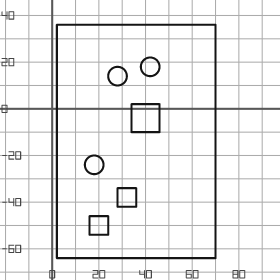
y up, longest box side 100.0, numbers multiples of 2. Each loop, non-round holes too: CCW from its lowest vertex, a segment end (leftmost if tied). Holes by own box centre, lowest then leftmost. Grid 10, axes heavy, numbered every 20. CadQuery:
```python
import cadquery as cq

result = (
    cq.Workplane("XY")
    .moveTo(2.0, -64.0)
    .lineTo(70.0, -64.0)
    .lineTo(70.0, 36.0)
    .lineTo(2.0, 36.0)
    .close()
    .moveTo(16.0, -54.0)
    .lineTo(24.0, -54.0)
    .lineTo(24.0, -46.0)
    .lineTo(16.0, -46.0)
    .close()
    .moveTo(28.0, -42.0)
    .lineTo(36.0, -42.0)
    .lineTo(36.0, -34.0)
    .lineTo(28.0, -34.0)
    .close()
    .moveTo(18.0, -24.0)
    .circle(4.0)
    .moveTo(34.0, -10.0)
    .lineTo(46.0, -10.0)
    .lineTo(46.0, 2.0)
    .lineTo(34.0, 2.0)
    .close()
    .moveTo(28.0, 14.0)
    .circle(4.0)
    .moveTo(42.0, 18.0)
    .circle(4.0)
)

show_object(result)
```